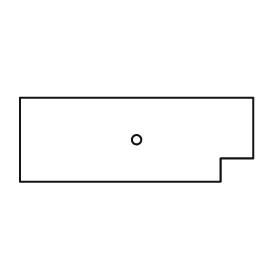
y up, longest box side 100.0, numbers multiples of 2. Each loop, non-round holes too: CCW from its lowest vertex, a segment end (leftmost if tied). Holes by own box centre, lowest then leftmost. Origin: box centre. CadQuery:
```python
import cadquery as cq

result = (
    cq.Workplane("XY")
    .moveTo(-50.0, -18.0)
    .lineTo(36.0, -18.0)
    .lineTo(36.0, -8.0)
    .lineTo(50.0, -8.0)
    .lineTo(50.0, 18.0)
    .lineTo(-50.0, 18.0)
    .close()
    .moveTo(0.0, 0.0)
    .circle(2.0)
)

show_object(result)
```